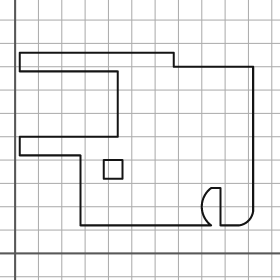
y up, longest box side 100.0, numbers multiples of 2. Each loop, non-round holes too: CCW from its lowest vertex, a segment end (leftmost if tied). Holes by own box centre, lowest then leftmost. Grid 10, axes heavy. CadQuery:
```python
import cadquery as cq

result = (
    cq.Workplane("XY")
    .moveTo(28.0, 12.0)
    .lineTo(84.0, 12.0)
    .threePointArc((80.0, 20.0), (84.0, 28.0))
    .lineTo(88.0, 28.0)
    .lineTo(88.0, 12.0)
    .lineTo(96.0, 12.0)
    .threePointArc((100.0, 14.0), (102.0, 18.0))
    .lineTo(102.0, 80.0)
    .lineTo(68.0, 80.0)
    .lineTo(68.0, 86.0)
    .lineTo(2.0, 86.0)
    .lineTo(2.0, 78.0)
    .lineTo(44.0, 78.0)
    .lineTo(44.0, 50.0)
    .lineTo(2.0, 50.0)
    .lineTo(2.0, 42.0)
    .lineTo(28.0, 42.0)
    .close()
    .moveTo(38.0, 32.0)
    .lineTo(46.0, 32.0)
    .lineTo(46.0, 40.0)
    .lineTo(38.0, 40.0)
    .close()
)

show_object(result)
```